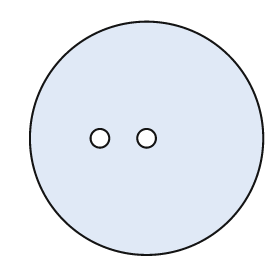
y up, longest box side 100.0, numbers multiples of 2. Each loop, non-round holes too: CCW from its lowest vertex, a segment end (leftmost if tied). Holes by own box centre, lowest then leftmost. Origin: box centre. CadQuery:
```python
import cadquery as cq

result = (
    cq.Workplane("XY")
    .moveTo(0.0, 0.0)
    .circle(50.0)
    .moveTo(-20.0, 0.0)
    .circle(4.0)
    .moveTo(0.0, 0.0)
    .circle(4.0)
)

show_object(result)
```